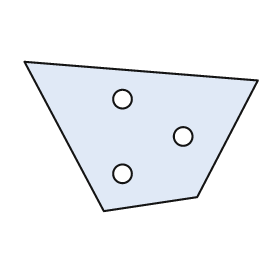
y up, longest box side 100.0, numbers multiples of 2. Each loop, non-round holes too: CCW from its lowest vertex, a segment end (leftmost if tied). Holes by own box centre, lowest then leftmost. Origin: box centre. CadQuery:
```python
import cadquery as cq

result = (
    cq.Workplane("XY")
    .moveTo(-16.0, -32.0)
    .lineTo(24.0, -26.0)
    .lineTo(50.0, 24.0)
    .lineTo(-50.0, 32.0)
    .close()
    .moveTo(-8.0, -16.0)
    .circle(4.0)
    .moveTo(18.0, 0.0)
    .circle(4.0)
    .moveTo(-8.0, 16.0)
    .circle(4.0)
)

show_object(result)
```